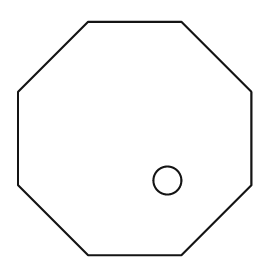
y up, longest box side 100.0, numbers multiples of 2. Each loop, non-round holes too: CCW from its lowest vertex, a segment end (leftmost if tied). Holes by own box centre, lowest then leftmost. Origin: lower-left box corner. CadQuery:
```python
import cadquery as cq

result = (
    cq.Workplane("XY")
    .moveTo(30.0, 0.0)
    .lineTo(70.0, 0.0)
    .lineTo(100.0, 30.0)
    .lineTo(100.0, 70.0)
    .lineTo(70.0, 100.0)
    .lineTo(30.0, 100.0)
    .lineTo(0.0, 70.0)
    .lineTo(0.0, 30.0)
    .close()
    .moveTo(64.0, 32.0)
    .circle(6.0)
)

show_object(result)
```